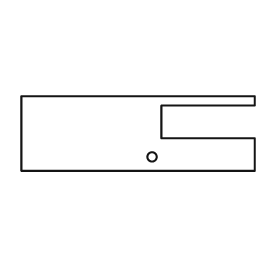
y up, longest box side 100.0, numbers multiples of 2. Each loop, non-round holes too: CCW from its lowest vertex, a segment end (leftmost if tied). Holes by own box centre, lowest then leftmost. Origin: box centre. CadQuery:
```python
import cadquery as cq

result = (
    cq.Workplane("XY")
    .moveTo(-50.0, -16.0)
    .lineTo(50.0, -16.0)
    .lineTo(50.0, -2.0)
    .lineTo(10.0, -2.0)
    .lineTo(10.0, 12.0)
    .lineTo(50.0, 12.0)
    .lineTo(50.0, 16.0)
    .lineTo(-50.0, 16.0)
    .close()
    .moveTo(6.0, -10.0)
    .circle(2.0)
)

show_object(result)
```